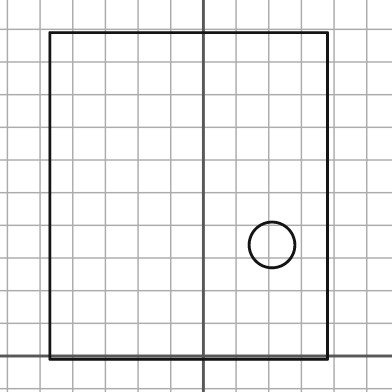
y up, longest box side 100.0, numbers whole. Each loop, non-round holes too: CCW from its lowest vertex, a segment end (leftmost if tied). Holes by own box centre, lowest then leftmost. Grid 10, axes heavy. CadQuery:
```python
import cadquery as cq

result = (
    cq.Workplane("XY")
    .moveTo(-47.0, -1.0)
    .lineTo(38.0, -1.0)
    .lineTo(38.0, 99.0)
    .lineTo(-47.0, 99.0)
    .close()
    .moveTo(21.0, 34.0)
    .circle(7.0)
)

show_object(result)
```